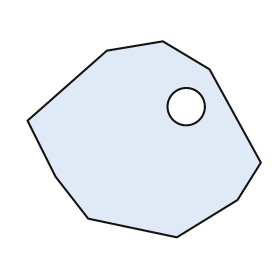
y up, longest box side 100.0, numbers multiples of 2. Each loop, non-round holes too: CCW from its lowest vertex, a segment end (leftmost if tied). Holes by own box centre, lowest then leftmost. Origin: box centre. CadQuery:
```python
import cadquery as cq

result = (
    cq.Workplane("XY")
    .moveTo(14.0, -42.0)
    .lineTo(40.0, -26.0)
    .lineTo(50.0, -10.0)
    .lineTo(28.0, 30.0)
    .lineTo(8.0, 42.0)
    .lineTo(-16.0, 38.0)
    .lineTo(-50.0, 8.0)
    .lineTo(-38.0, -16.0)
    .lineTo(-24.0, -34.0)
    .close()
    .moveTo(18.0, 14.0)
    .circle(8.0)
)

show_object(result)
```